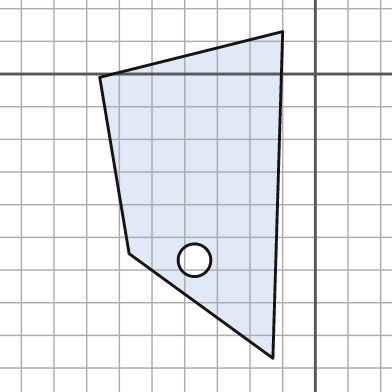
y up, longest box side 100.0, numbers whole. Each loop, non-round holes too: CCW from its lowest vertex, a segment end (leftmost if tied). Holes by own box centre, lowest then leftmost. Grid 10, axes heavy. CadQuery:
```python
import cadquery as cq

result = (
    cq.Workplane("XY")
    .moveTo(-13.0, -87.0)
    .lineTo(-10.0, 13.0)
    .lineTo(-66.0, -1.0)
    .lineTo(-57.0, -55.0)
    .close()
    .moveTo(-37.0, -57.0)
    .circle(5.0)
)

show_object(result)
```